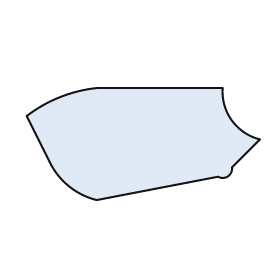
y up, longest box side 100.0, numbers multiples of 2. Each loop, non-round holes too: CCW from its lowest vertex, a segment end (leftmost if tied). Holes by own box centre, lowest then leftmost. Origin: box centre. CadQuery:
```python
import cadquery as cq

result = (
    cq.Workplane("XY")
    .moveTo(-20.0, -24.0)
    .lineTo(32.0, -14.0)
    .threePointArc((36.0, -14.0), (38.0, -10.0))
    .lineTo(50.0, 2.0)
    .threePointArc((38.0, 10.0), (34.0, 24.0))
    .lineTo(-20.0, 24.0)
    .threePointArc((-36.0, 20.0), (-50.0, 12.0))
    .lineTo(-40.0, -8.0)
    .threePointArc((-32.0, -18.0), (-20.0, -24.0))
    .close()
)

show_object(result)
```